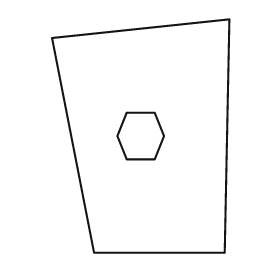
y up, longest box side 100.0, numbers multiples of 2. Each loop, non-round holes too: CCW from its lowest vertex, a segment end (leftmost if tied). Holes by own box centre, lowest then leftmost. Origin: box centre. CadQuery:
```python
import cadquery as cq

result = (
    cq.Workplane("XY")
    .moveTo(-20.0, -50.0)
    .lineTo(36.0, -50.0)
    .lineTo(38.0, 50.0)
    .lineTo(-38.0, 42.0)
    .close()
    .moveTo(-6.0, -10.0)
    .lineTo(6.0, -10.0)
    .lineTo(10.0, 0.0)
    .lineTo(6.0, 10.0)
    .lineTo(-6.0, 10.0)
    .lineTo(-10.0, 0.0)
    .close()
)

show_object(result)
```